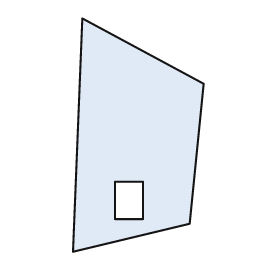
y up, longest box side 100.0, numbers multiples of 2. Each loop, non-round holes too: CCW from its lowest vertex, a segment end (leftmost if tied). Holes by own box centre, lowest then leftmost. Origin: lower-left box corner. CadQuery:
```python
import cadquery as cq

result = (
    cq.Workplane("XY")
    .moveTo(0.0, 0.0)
    .lineTo(50.0, 12.0)
    .lineTo(56.0, 72.0)
    .lineTo(4.0, 100.0)
    .close()
    .moveTo(18.0, 14.0)
    .lineTo(30.0, 14.0)
    .lineTo(30.0, 30.0)
    .lineTo(18.0, 30.0)
    .close()
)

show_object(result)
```